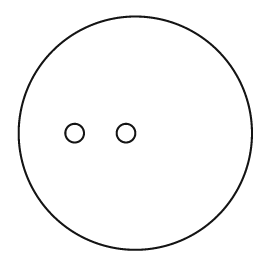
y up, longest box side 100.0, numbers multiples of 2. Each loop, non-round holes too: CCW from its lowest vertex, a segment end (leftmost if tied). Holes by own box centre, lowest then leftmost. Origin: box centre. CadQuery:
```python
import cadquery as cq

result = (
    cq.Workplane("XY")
    .moveTo(0.0, 0.0)
    .circle(50.0)
    .moveTo(-26.0, 0.0)
    .circle(4.0)
    .moveTo(-4.0, 0.0)
    .circle(4.0)
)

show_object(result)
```